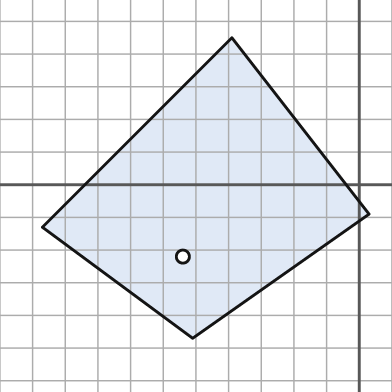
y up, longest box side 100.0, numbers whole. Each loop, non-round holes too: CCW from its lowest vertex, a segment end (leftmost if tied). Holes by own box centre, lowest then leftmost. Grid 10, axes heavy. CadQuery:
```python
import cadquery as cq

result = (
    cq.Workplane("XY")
    .moveTo(-51.0, -47.0)
    .lineTo(3.0, -9.0)
    .lineTo(-39.0, 45.0)
    .lineTo(-97.0, -13.0)
    .close()
    .moveTo(-54.0, -22.0)
    .circle(2.0)
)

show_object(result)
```